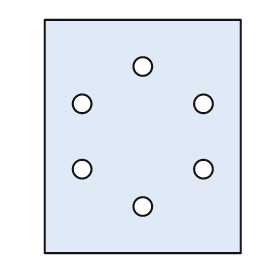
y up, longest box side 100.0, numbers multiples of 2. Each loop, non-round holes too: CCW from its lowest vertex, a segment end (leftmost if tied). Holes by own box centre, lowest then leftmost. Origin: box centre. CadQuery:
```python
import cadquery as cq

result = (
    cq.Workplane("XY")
    .moveTo(-42.0, -50.0)
    .lineTo(42.0, -50.0)
    .lineTo(42.0, 50.0)
    .lineTo(-42.0, 50.0)
    .close()
    .moveTo(0.0, -30.0)
    .circle(4.0)
    .moveTo(-26.0, -14.0)
    .circle(4.0)
    .moveTo(26.0, -14.0)
    .circle(4.0)
    .moveTo(-26.0, 14.0)
    .circle(4.0)
    .moveTo(26.0, 14.0)
    .circle(4.0)
    .moveTo(0.0, 30.0)
    .circle(4.0)
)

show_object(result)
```